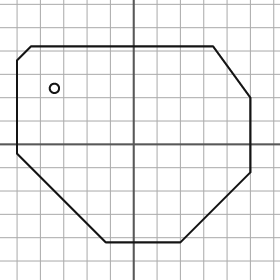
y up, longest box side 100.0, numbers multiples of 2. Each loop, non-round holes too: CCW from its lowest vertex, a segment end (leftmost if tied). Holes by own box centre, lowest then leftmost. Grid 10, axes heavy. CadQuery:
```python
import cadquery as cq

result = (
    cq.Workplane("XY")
    .moveTo(-12.0, -42.0)
    .lineTo(20.0, -42.0)
    .lineTo(50.0, -12.0)
    .lineTo(50.0, 20.0)
    .lineTo(34.0, 42.0)
    .lineTo(-44.0, 42.0)
    .lineTo(-50.0, 36.0)
    .lineTo(-50.0, -4.0)
    .close()
    .moveTo(-34.0, 24.0)
    .circle(2.0)
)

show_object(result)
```